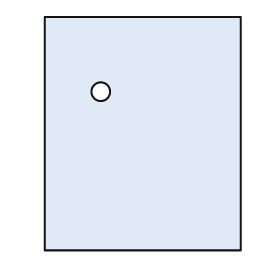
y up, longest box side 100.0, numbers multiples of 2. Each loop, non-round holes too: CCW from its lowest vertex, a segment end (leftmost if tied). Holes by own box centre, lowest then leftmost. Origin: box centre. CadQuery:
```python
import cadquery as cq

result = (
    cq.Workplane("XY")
    .moveTo(-42.0, -50.0)
    .lineTo(42.0, -50.0)
    .lineTo(42.0, 50.0)
    .lineTo(-42.0, 50.0)
    .close()
    .moveTo(-18.0, 18.0)
    .circle(4.0)
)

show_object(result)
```